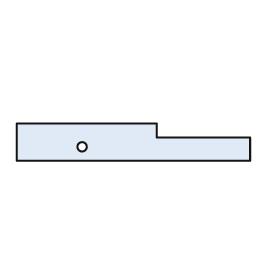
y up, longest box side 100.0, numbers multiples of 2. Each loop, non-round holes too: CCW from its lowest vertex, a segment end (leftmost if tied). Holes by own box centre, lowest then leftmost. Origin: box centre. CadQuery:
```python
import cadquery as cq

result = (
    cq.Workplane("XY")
    .moveTo(-50.0, -8.0)
    .lineTo(50.0, -8.0)
    .lineTo(50.0, 2.0)
    .lineTo(10.0, 2.0)
    .lineTo(10.0, 8.0)
    .lineTo(-50.0, 8.0)
    .close()
    .moveTo(-22.0, -2.0)
    .circle(2.0)
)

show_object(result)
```